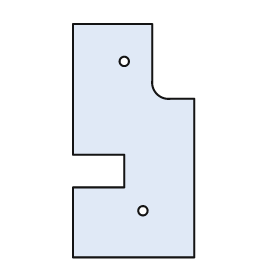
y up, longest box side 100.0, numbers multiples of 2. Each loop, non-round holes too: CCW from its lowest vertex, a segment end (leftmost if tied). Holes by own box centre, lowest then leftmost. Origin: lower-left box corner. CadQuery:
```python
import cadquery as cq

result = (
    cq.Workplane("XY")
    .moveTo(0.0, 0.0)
    .lineTo(52.0, 0.0)
    .lineTo(52.0, 68.0)
    .lineTo(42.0, 68.0)
    .threePointArc((36.0, 70.0), (34.0, 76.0))
    .lineTo(34.0, 100.0)
    .lineTo(0.0, 100.0)
    .lineTo(0.0, 44.0)
    .lineTo(22.0, 44.0)
    .lineTo(22.0, 30.0)
    .lineTo(0.0, 30.0)
    .close()
    .moveTo(30.0, 20.0)
    .circle(2.0)
    .moveTo(22.0, 84.0)
    .circle(2.0)
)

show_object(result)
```